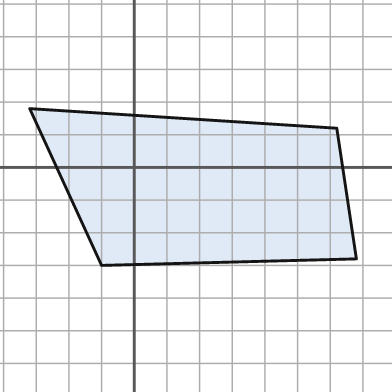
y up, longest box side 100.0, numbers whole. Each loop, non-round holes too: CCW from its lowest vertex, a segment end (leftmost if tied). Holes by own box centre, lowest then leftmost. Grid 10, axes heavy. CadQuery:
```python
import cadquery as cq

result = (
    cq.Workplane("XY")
    .moveTo(-10.0, -30.0)
    .lineTo(68.0, -28.0)
    .lineTo(62.0, 12.0)
    .lineTo(-32.0, 18.0)
    .close()
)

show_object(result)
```